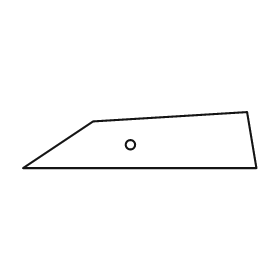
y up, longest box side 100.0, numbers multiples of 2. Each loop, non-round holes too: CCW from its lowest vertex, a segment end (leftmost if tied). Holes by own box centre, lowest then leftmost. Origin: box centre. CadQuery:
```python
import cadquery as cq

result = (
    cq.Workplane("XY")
    .moveTo(-50.0, -12.0)
    .lineTo(50.0, -12.0)
    .lineTo(46.0, 12.0)
    .lineTo(-20.0, 8.0)
    .close()
    .moveTo(-4.0, -2.0)
    .circle(2.0)
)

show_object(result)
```